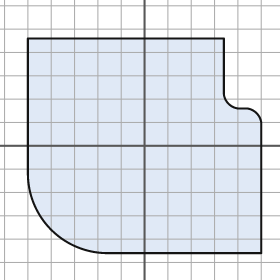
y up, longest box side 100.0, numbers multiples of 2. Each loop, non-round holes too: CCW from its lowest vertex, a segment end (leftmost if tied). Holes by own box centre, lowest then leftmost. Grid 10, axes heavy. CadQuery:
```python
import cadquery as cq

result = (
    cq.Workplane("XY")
    .moveTo(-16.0, -46.0)
    .lineTo(50.0, -46.0)
    .lineTo(50.0, 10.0)
    .threePointArc((48.0, 14.0), (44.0, 16.0))
    .lineTo(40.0, 16.0)
    .threePointArc((36.0, 18.0), (34.0, 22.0))
    .lineTo(34.0, 46.0)
    .lineTo(-50.0, 46.0)
    .lineTo(-50.0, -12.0)
    .threePointArc((-40.0, -36.0), (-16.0, -46.0))
    .close()
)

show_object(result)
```